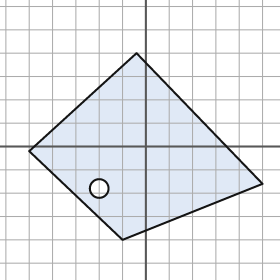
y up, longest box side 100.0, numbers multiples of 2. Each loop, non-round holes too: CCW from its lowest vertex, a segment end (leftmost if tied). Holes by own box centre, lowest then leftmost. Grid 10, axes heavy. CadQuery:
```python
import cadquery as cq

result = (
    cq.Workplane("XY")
    .moveTo(-10.0, -40.0)
    .lineTo(50.0, -16.0)
    .lineTo(-4.0, 40.0)
    .lineTo(-50.0, -2.0)
    .close()
    .moveTo(-20.0, -18.0)
    .circle(4.0)
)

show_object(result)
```